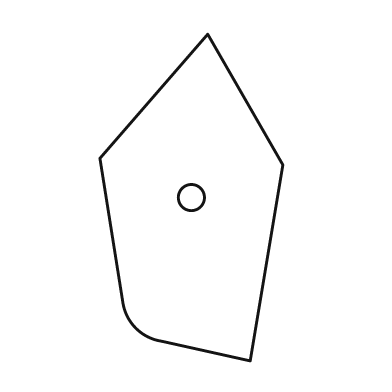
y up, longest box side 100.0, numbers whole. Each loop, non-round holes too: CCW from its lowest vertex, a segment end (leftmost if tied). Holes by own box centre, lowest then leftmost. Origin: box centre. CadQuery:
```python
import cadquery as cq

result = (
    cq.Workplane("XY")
    .moveTo(18.0, -50.0)
    .lineTo(28.0, 10.0)
    .lineTo(5.0, 50.0)
    .lineTo(-28.0, 12.0)
    .lineTo(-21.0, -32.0)
    .threePointArc((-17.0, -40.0), (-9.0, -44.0))
    .close()
    .moveTo(0.0, 0.0)
    .circle(4.0)
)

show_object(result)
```